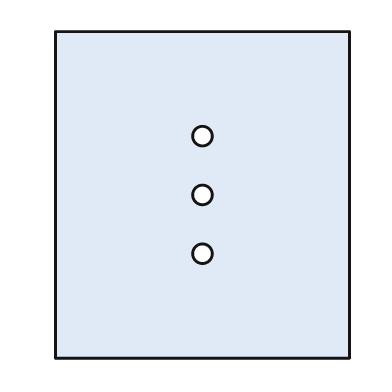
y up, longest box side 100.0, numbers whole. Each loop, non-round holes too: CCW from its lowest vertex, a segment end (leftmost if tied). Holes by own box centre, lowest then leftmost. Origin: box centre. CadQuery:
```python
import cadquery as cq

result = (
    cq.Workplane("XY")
    .moveTo(-45.0, -50.0)
    .lineTo(45.0, -50.0)
    .lineTo(45.0, 50.0)
    .lineTo(-45.0, 50.0)
    .close()
    .moveTo(0.0, -18.0)
    .circle(3.0)
    .moveTo(0.0, 0.0)
    .circle(3.0)
    .moveTo(0.0, 18.0)
    .circle(3.0)
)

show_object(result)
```